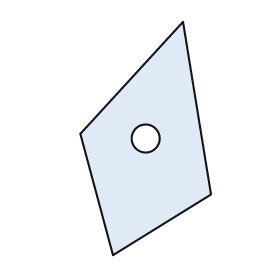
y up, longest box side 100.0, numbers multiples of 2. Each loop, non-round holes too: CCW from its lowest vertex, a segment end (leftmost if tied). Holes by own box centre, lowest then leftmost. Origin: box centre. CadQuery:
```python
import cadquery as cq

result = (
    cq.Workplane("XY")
    .moveTo(-14.0, -50.0)
    .lineTo(28.0, -24.0)
    .lineTo(16.0, 50.0)
    .lineTo(-28.0, 2.0)
    .close()
    .moveTo(0.0, 0.0)
    .circle(6.0)
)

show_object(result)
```